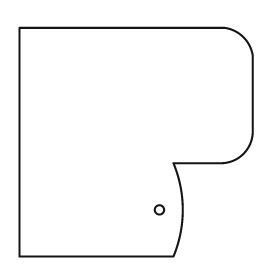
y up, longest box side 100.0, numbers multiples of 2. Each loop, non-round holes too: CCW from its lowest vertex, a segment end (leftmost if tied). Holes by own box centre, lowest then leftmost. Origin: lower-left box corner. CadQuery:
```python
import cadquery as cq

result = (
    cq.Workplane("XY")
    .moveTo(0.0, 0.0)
    .lineTo(66.0, 0.0)
    .threePointArc((70.0, 20.0), (66.0, 40.0))
    .lineTo(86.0, 40.0)
    .threePointArc((96.0, 44.0), (100.0, 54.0))
    .lineTo(100.0, 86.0)
    .threePointArc((96.0, 94.0), (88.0, 98.0))
    .lineTo(0.0, 98.0)
    .close()
    .moveTo(60.0, 20.0)
    .circle(2.0)
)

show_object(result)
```